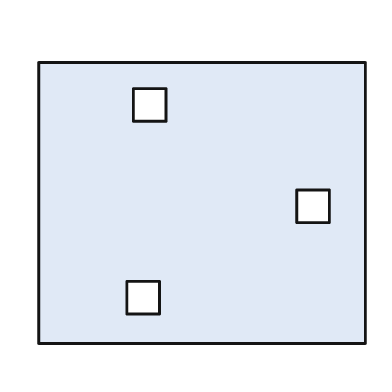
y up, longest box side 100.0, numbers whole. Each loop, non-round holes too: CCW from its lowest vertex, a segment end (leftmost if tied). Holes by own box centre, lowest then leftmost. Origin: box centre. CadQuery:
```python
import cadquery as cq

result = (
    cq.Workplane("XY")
    .moveTo(-50.0, -43.0)
    .lineTo(50.0, -43.0)
    .lineTo(50.0, 43.0)
    .lineTo(-50.0, 43.0)
    .close()
    .moveTo(-23.0, -34.0)
    .lineTo(-13.0, -34.0)
    .lineTo(-13.0, -24.0)
    .lineTo(-23.0, -24.0)
    .close()
    .moveTo(29.0, -6.0)
    .lineTo(39.0, -6.0)
    .lineTo(39.0, 4.0)
    .lineTo(29.0, 4.0)
    .close()
    .moveTo(-21.0, 25.0)
    .lineTo(-11.0, 25.0)
    .lineTo(-11.0, 35.0)
    .lineTo(-21.0, 35.0)
    .close()
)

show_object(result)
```